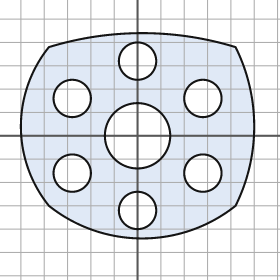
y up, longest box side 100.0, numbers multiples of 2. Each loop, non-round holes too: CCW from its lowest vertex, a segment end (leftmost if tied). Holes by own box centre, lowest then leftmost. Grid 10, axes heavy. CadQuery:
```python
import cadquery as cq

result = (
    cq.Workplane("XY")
    .moveTo(-38.0, -30.0)
    .threePointArc((2.0, -44.0), (42.0, -30.0))
    .threePointArc((50.0, 4.0), (42.0, 38.0))
    .threePointArc((2.0, 44.0), (-38.0, 38.0))
    .threePointArc((-50.0, 4.0), (-38.0, -30.0))
    .close()
    .moveTo(0.0, -32.0)
    .circle(8.0)
    .moveTo(-28.0, -16.0)
    .circle(8.0)
    .moveTo(28.0, -16.0)
    .circle(8.0)
    .moveTo(0.0, 0.0)
    .circle(14.0)
    .moveTo(-28.0, 16.0)
    .circle(8.0)
    .moveTo(28.0, 16.0)
    .circle(8.0)
    .moveTo(0.0, 32.0)
    .circle(8.0)
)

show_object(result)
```